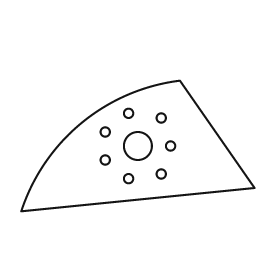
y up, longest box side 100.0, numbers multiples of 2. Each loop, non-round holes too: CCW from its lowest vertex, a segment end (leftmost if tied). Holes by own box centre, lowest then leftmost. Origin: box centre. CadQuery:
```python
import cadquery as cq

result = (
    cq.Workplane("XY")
    .moveTo(-50.0, -28.0)
    .lineTo(50.0, -18.0)
    .lineTo(18.0, 28.0)
    .threePointArc((-24.0, 10.0), (-50.0, -28.0))
    .close()
    .moveTo(-4.0, -14.0)
    .circle(2.0)
    .moveTo(10.0, -12.0)
    .circle(2.0)
    .moveTo(-14.0, -6.0)
    .circle(2.0)
    .moveTo(0.0, 0.0)
    .circle(6.0)
    .moveTo(14.0, 0.0)
    .circle(2.0)
    .moveTo(-14.0, 6.0)
    .circle(2.0)
    .moveTo(10.0, 12.0)
    .circle(2.0)
    .moveTo(-4.0, 14.0)
    .circle(2.0)
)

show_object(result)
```